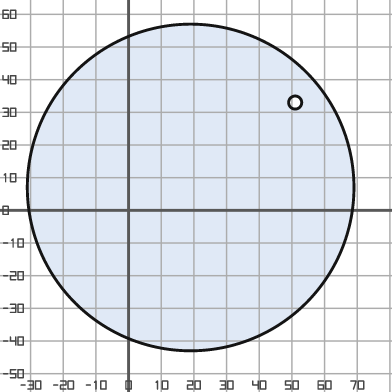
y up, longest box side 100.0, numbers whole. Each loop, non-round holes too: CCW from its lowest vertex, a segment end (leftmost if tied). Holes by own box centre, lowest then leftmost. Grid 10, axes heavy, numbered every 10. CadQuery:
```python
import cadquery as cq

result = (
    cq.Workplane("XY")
    .moveTo(19.0, 7.0)
    .circle(50.0)
    .moveTo(51.0, 33.0)
    .circle(2.0)
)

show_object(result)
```